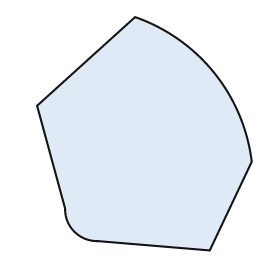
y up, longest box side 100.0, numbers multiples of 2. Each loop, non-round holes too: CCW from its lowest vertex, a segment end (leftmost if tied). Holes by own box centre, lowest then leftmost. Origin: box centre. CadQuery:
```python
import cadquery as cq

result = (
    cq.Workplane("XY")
    .moveTo(28.0, -50.0)
    .lineTo(46.0, -12.0)
    .threePointArc((30.0, 26.0), (-4.0, 50.0))
    .lineTo(-46.0, 12.0)
    .lineTo(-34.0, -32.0)
    .threePointArc((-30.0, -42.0), (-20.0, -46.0))
    .close()
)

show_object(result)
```